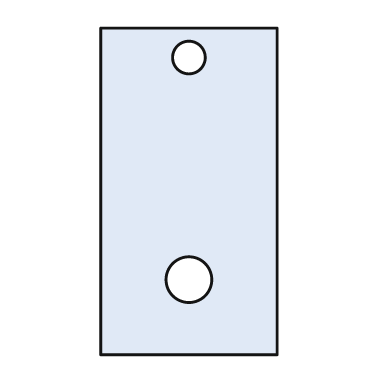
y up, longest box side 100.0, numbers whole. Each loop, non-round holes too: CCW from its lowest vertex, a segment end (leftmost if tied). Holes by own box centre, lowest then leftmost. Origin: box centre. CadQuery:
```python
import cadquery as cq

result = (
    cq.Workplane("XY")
    .moveTo(-27.0, -50.0)
    .lineTo(27.0, -50.0)
    .lineTo(27.0, 50.0)
    .lineTo(-27.0, 50.0)
    .close()
    .moveTo(0.0, -27.0)
    .circle(7.0)
    .moveTo(0.0, 41.0)
    .circle(5.0)
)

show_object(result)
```